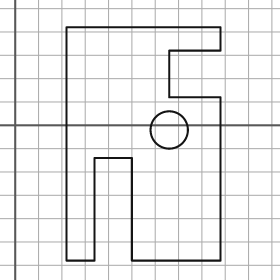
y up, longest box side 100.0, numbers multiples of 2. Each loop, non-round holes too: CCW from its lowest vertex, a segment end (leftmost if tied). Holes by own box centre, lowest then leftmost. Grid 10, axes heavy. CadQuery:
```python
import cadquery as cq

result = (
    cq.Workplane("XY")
    .moveTo(22.0, -58.0)
    .lineTo(34.0, -58.0)
    .lineTo(34.0, -14.0)
    .lineTo(50.0, -14.0)
    .lineTo(50.0, -58.0)
    .lineTo(88.0, -58.0)
    .lineTo(88.0, 12.0)
    .lineTo(66.0, 12.0)
    .lineTo(66.0, 32.0)
    .lineTo(88.0, 32.0)
    .lineTo(88.0, 42.0)
    .lineTo(22.0, 42.0)
    .close()
    .moveTo(66.0, -2.0)
    .circle(8.0)
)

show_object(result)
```